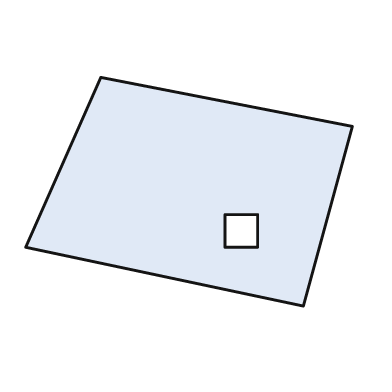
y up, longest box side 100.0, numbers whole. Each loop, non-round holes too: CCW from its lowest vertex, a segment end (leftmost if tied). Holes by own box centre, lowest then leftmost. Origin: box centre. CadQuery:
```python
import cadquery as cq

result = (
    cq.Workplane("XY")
    .moveTo(35.0, -35.0)
    .lineTo(50.0, 20.0)
    .lineTo(-27.0, 35.0)
    .lineTo(-50.0, -17.0)
    .close()
    .moveTo(11.0, -17.0)
    .lineTo(21.0, -17.0)
    .lineTo(21.0, -7.0)
    .lineTo(11.0, -7.0)
    .close()
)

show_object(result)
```